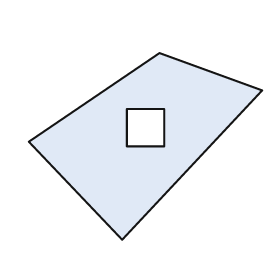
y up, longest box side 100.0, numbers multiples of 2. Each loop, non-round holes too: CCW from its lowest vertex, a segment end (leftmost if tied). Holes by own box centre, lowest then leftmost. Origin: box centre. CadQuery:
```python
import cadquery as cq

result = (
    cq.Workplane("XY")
    .moveTo(-10.0, -40.0)
    .lineTo(50.0, 24.0)
    .lineTo(6.0, 40.0)
    .lineTo(-50.0, 2.0)
    .close()
    .moveTo(-8.0, 0.0)
    .lineTo(8.0, 0.0)
    .lineTo(8.0, 16.0)
    .lineTo(-8.0, 16.0)
    .close()
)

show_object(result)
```